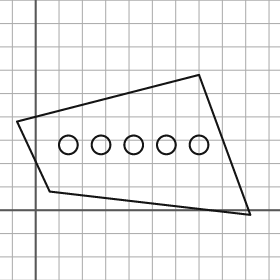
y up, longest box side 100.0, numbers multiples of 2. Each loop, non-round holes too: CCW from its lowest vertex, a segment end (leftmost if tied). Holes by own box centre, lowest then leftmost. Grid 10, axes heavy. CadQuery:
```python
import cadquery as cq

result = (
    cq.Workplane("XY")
    .moveTo(92.0, -2.0)
    .lineTo(70.0, 58.0)
    .lineTo(-8.0, 38.0)
    .lineTo(6.0, 8.0)
    .close()
    .moveTo(14.0, 28.0)
    .circle(4.0)
    .moveTo(28.0, 28.0)
    .circle(4.0)
    .moveTo(42.0, 28.0)
    .circle(4.0)
    .moveTo(56.0, 28.0)
    .circle(4.0)
    .moveTo(70.0, 28.0)
    .circle(4.0)
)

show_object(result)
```